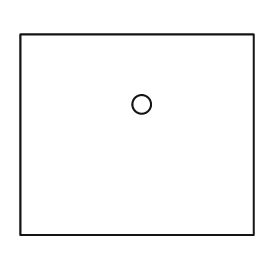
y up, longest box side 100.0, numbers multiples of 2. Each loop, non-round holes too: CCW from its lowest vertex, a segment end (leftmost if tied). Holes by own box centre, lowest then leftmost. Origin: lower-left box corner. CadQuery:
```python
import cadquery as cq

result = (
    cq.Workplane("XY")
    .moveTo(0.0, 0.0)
    .lineTo(100.0, 0.0)
    .lineTo(100.0, 86.0)
    .lineTo(0.0, 86.0)
    .close()
    .moveTo(52.0, 56.0)
    .circle(4.0)
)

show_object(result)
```